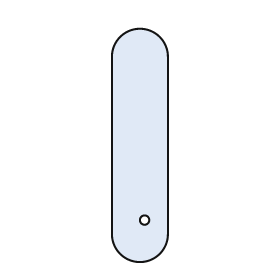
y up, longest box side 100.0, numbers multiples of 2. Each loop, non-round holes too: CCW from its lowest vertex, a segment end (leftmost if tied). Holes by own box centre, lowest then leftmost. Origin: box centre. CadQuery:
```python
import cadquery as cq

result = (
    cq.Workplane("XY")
    .moveTo(-12.0, -38.0)
    .threePointArc((0.0, -50.0), (12.0, -38.0))
    .lineTo(12.0, 38.0)
    .threePointArc((0.0, 50.0), (-12.0, 38.0))
    .close()
    .moveTo(2.0, -32.0)
    .circle(2.0)
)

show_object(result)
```